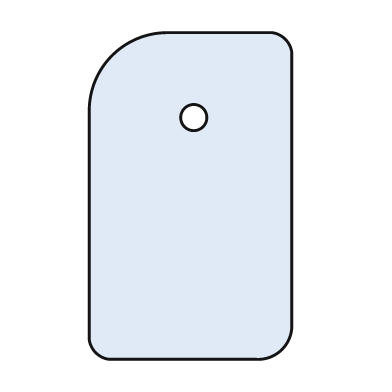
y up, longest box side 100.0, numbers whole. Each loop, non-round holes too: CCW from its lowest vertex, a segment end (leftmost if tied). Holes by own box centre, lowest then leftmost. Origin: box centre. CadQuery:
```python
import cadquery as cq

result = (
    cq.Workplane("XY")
    .moveTo(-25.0, -50.0)
    .lineTo(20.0, -50.0)
    .threePointArc((28.0, -47.0), (31.0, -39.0))
    .lineTo(31.0, 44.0)
    .threePointArc((29.0, 48.0), (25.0, 50.0))
    .lineTo(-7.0, 50.0)
    .threePointArc((-24.0, 43.0), (-31.0, 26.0))
    .lineTo(-31.0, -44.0)
    .threePointArc((-29.0, -48.0), (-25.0, -50.0))
    .close()
    .moveTo(1.0, 24.0)
    .circle(4.0)
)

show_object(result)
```